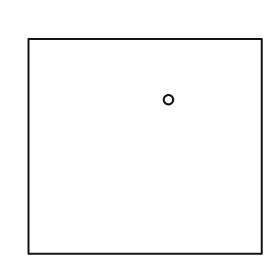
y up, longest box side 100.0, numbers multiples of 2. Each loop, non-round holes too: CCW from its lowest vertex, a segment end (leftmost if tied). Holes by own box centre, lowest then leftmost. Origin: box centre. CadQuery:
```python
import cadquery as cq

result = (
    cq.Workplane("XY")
    .moveTo(-50.0, -46.0)
    .lineTo(50.0, -46.0)
    .lineTo(50.0, 46.0)
    .lineTo(-50.0, 46.0)
    .close()
    .moveTo(10.0, 20.0)
    .circle(2.0)
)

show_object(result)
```